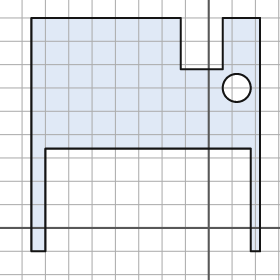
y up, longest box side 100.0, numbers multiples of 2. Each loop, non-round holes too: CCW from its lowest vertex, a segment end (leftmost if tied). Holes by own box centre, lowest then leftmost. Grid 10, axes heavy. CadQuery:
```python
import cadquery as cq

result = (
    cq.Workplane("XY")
    .moveTo(-76.0, -10.0)
    .lineTo(-70.0, -10.0)
    .lineTo(-70.0, 34.0)
    .lineTo(18.0, 34.0)
    .lineTo(18.0, -10.0)
    .lineTo(22.0, -10.0)
    .lineTo(22.0, 90.0)
    .lineTo(6.0, 90.0)
    .lineTo(6.0, 68.0)
    .lineTo(-12.0, 68.0)
    .lineTo(-12.0, 90.0)
    .lineTo(-76.0, 90.0)
    .close()
    .moveTo(12.0, 60.0)
    .circle(6.0)
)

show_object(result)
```